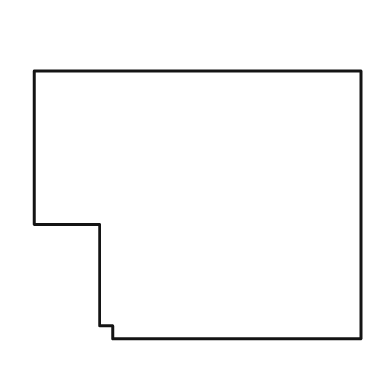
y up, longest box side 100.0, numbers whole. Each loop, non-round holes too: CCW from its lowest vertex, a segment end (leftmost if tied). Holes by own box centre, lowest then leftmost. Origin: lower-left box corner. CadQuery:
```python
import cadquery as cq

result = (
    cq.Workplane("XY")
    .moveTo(24.0, 0.0)
    .lineTo(100.0, 0.0)
    .lineTo(100.0, 82.0)
    .lineTo(0.0, 82.0)
    .lineTo(0.0, 35.0)
    .lineTo(20.0, 35.0)
    .lineTo(20.0, 4.0)
    .lineTo(24.0, 4.0)
    .close()
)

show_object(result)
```